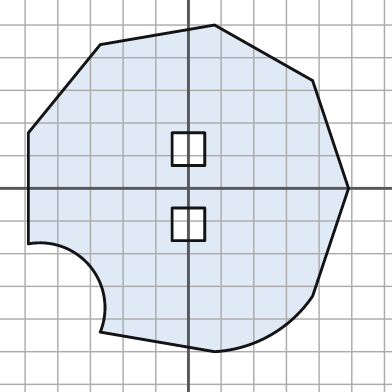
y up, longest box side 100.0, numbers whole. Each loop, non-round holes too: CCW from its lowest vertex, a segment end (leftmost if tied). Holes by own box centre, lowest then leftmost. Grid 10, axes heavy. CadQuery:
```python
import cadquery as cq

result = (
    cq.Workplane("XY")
    .moveTo(8.0, -50.0)
    .threePointArc((25.0, -45.0), (38.0, -33.0))
    .lineTo(49.0, 0.0)
    .lineTo(38.0, 33.0)
    .lineTo(8.0, 50.0)
    .lineTo(-27.0, 44.0)
    .lineTo(-49.0, 17.0)
    .lineTo(-49.0, -17.0)
    .threePointArc((-30.0, -24.0), (-27.0, -44.0))
    .close()
    .moveTo(-5.0, -16.0)
    .lineTo(5.0, -16.0)
    .lineTo(5.0, -6.0)
    .lineTo(-5.0, -6.0)
    .close()
    .moveTo(-5.0, 7.0)
    .lineTo(5.0, 7.0)
    .lineTo(5.0, 17.0)
    .lineTo(-5.0, 17.0)
    .close()
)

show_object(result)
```